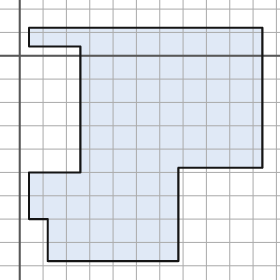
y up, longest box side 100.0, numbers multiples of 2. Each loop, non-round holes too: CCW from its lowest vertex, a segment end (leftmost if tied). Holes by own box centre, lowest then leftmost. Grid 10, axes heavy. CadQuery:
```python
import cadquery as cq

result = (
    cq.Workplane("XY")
    .moveTo(12.0, -88.0)
    .lineTo(68.0, -88.0)
    .lineTo(68.0, -48.0)
    .lineTo(104.0, -48.0)
    .lineTo(104.0, 12.0)
    .lineTo(4.0, 12.0)
    .lineTo(4.0, 4.0)
    .lineTo(26.0, 4.0)
    .lineTo(26.0, -50.0)
    .lineTo(4.0, -50.0)
    .lineTo(4.0, -70.0)
    .lineTo(12.0, -70.0)
    .close()
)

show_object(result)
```